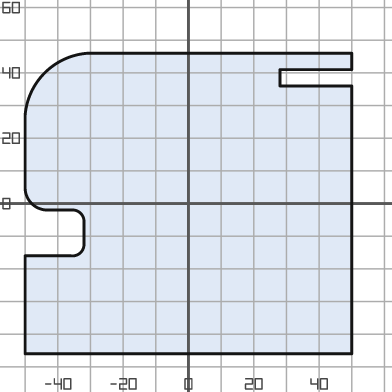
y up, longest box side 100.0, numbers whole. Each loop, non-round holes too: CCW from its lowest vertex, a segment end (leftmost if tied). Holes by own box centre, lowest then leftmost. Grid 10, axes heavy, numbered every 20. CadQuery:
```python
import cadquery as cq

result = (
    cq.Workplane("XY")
    .moveTo(-50.0, -46.0)
    .lineTo(50.0, -46.0)
    .lineTo(50.0, 36.0)
    .lineTo(28.0, 36.0)
    .lineTo(28.0, 41.0)
    .lineTo(50.0, 41.0)
    .lineTo(50.0, 46.0)
    .lineTo(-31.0, 46.0)
    .threePointArc((-44.0, 40.0), (-50.0, 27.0))
    .lineTo(-50.0, 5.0)
    .threePointArc((-48.0, 0.0), (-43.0, -2.0))
    .lineTo(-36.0, -2.0)
    .threePointArc((-33.0, -3.0), (-32.0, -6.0))
    .lineTo(-32.0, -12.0)
    .threePointArc((-33.0, -15.0), (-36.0, -16.0))
    .lineTo(-50.0, -16.0)
    .close()
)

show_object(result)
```